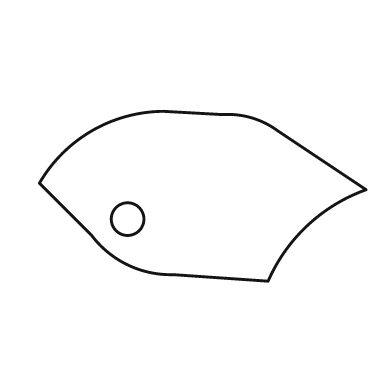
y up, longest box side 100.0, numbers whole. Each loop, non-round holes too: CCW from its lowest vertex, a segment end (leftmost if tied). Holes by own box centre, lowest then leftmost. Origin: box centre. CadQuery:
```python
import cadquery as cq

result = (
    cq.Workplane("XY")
    .moveTo(20.0, -26.0)
    .threePointArc((32.0, -9.0), (50.0, 2.0))
    .lineTo(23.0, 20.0)
    .threePointArc((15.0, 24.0), (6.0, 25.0))
    .lineTo(-12.0, 26.0)
    .threePointArc((-34.0, 20.0), (-50.0, 4.0))
    .lineTo(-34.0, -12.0)
    .threePointArc((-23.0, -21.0), (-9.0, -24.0))
    .close()
    .moveTo(-23.0, -7.0)
    .circle(5.0)
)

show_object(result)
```